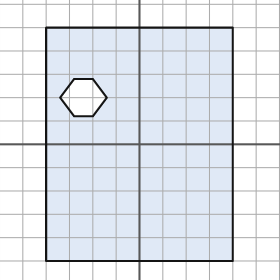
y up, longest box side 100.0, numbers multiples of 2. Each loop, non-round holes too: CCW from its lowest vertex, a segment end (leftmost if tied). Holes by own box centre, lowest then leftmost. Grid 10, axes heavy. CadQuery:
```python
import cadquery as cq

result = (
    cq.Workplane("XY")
    .moveTo(-40.0, -50.0)
    .lineTo(40.0, -50.0)
    .lineTo(40.0, 50.0)
    .lineTo(-40.0, 50.0)
    .close()
    .moveTo(-28.0, 12.0)
    .lineTo(-20.0, 12.0)
    .lineTo(-14.0, 20.0)
    .lineTo(-20.0, 28.0)
    .lineTo(-28.0, 28.0)
    .lineTo(-34.0, 20.0)
    .close()
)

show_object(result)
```